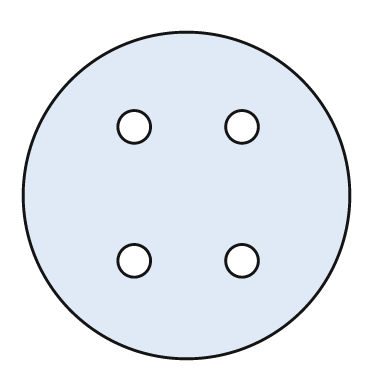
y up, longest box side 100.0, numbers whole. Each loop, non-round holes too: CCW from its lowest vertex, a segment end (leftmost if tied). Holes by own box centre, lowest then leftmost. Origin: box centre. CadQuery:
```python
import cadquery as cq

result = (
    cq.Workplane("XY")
    .moveTo(0.0, 0.0)
    .circle(50.0)
    .moveTo(-16.0, -20.0)
    .circle(5.0)
    .moveTo(17.0, -20.0)
    .circle(5.0)
    .moveTo(-16.0, 21.0)
    .circle(5.0)
    .moveTo(17.0, 21.0)
    .circle(5.0)
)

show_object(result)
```